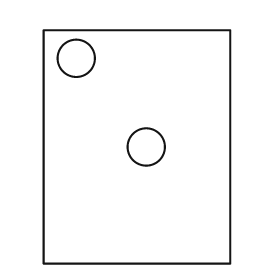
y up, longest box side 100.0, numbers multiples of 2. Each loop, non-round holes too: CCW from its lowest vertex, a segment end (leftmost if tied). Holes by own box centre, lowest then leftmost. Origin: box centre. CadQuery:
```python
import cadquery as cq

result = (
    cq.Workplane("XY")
    .moveTo(-40.0, -50.0)
    .lineTo(40.0, -50.0)
    .lineTo(40.0, 50.0)
    .lineTo(-40.0, 50.0)
    .close()
    .moveTo(4.0, 0.0)
    .circle(8.0)
    .moveTo(-26.0, 38.0)
    .circle(8.0)
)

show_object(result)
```